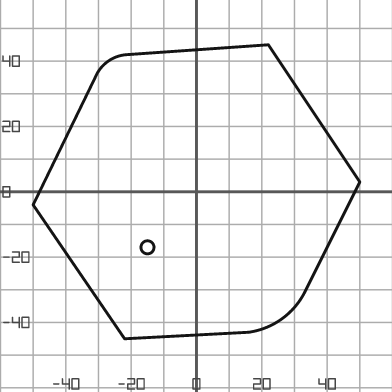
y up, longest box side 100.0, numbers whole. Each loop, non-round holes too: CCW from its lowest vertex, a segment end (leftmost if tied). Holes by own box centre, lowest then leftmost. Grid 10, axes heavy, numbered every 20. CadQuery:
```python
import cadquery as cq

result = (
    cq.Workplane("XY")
    .moveTo(-22.0, -45.0)
    .lineTo(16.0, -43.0)
    .threePointArc((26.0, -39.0), (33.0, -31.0))
    .lineTo(50.0, 3.0)
    .lineTo(22.0, 45.0)
    .lineTo(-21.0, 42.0)
    .threePointArc((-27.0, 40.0), (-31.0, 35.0))
    .lineTo(-50.0, -4.0)
    .close()
    .moveTo(-15.0, -17.0)
    .circle(2.0)
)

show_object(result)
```